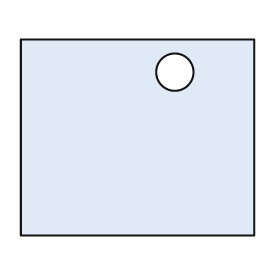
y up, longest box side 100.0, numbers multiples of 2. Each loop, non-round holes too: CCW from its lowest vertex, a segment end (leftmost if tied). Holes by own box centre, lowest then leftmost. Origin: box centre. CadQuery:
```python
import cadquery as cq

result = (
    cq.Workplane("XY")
    .moveTo(-50.0, -42.0)
    .lineTo(50.0, -42.0)
    .lineTo(50.0, 42.0)
    .lineTo(-50.0, 42.0)
    .close()
    .moveTo(16.0, 28.0)
    .circle(8.0)
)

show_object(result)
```